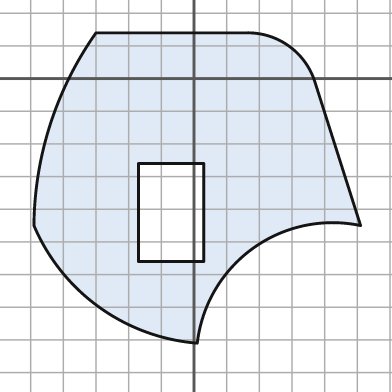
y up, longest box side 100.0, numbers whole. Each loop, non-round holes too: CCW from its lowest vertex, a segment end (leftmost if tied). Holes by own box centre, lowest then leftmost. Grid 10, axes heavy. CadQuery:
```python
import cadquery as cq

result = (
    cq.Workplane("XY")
    .moveTo(1.0, -81.0)
    .threePointArc((18.0, -52.0), (51.0, -45.0))
    .lineTo(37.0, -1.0)
    .threePointArc((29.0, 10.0), (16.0, 14.0))
    .lineTo(-30.0, 14.0)
    .threePointArc((-44.0, -14.0), (-49.0, -45.0))
    .threePointArc((-29.0, -70.0), (1.0, -81.0))
    .close()
    .moveTo(-17.0, -56.0)
    .lineTo(3.0, -56.0)
    .lineTo(3.0, -26.0)
    .lineTo(-17.0, -26.0)
    .close()
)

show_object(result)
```